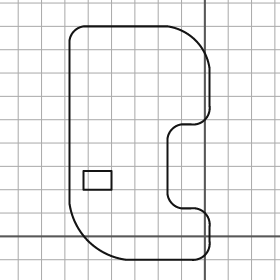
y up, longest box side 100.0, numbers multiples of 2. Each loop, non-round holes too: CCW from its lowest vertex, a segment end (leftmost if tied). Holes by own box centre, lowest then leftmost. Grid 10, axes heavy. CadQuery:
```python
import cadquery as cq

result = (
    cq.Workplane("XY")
    .moveTo(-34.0, -10.0)
    .lineTo(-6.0, -10.0)
    .threePointArc((0.0, -8.0), (2.0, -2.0))
    .lineTo(2.0, 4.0)
    .threePointArc((0.0, 10.0), (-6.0, 12.0))
    .lineTo(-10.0, 12.0)
    .threePointArc((-14.0, 14.0), (-16.0, 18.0))
    .lineTo(-16.0, 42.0)
    .threePointArc((-14.0, 46.0), (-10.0, 48.0))
    .lineTo(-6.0, 48.0)
    .threePointArc((0.0, 50.0), (2.0, 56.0))
    .lineTo(2.0, 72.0)
    .threePointArc((-4.0, 84.0), (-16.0, 90.0))
    .lineTo(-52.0, 90.0)
    .threePointArc((-56.0, 88.0), (-58.0, 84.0))
    .lineTo(-58.0, 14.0)
    .threePointArc((-50.0, -2.0), (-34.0, -10.0))
    .close()
    .moveTo(-52.0, 20.0)
    .lineTo(-40.0, 20.0)
    .lineTo(-40.0, 28.0)
    .lineTo(-52.0, 28.0)
    .close()
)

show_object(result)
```